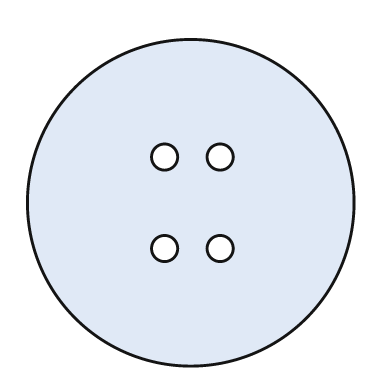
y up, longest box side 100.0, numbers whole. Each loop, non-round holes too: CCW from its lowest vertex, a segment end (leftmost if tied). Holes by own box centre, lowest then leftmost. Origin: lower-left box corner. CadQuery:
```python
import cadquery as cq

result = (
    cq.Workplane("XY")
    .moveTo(50.0, 50.0)
    .circle(50.0)
    .moveTo(42.0, 36.0)
    .circle(4.0)
    .moveTo(59.0, 36.0)
    .circle(4.0)
    .moveTo(42.0, 64.0)
    .circle(4.0)
    .moveTo(59.0, 64.0)
    .circle(4.0)
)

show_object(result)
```